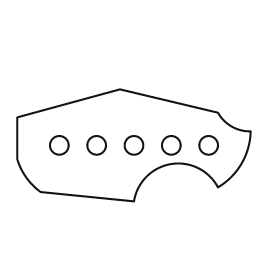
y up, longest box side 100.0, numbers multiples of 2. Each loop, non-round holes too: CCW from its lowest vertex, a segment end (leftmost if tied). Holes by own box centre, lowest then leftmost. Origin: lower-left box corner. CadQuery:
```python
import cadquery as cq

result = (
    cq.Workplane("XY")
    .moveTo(50.0, 0.0)
    .threePointArc((66.0, 16.0), (86.0, 6.0))
    .threePointArc((96.0, 16.0), (100.0, 30.0))
    .threePointArc((92.0, 32.0), (86.0, 38.0))
    .lineTo(44.0, 48.0)
    .lineTo(0.0, 36.0)
    .lineTo(0.0, 18.0)
    .threePointArc((4.0, 10.0), (10.0, 4.0))
    .close()
    .moveTo(18.0, 24.0)
    .circle(4.0)
    .moveTo(34.0, 24.0)
    .circle(4.0)
    .moveTo(50.0, 24.0)
    .circle(4.0)
    .moveTo(66.0, 24.0)
    .circle(4.0)
    .moveTo(82.0, 24.0)
    .circle(4.0)
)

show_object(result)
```